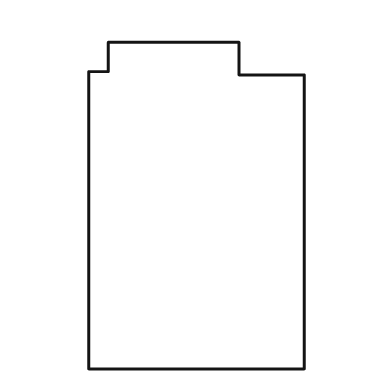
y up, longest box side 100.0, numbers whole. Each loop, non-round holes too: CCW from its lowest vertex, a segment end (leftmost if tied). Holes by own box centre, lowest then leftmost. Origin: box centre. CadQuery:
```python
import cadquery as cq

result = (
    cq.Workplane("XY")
    .moveTo(-33.0, -50.0)
    .lineTo(33.0, -50.0)
    .lineTo(33.0, 40.0)
    .lineTo(13.0, 40.0)
    .lineTo(13.0, 50.0)
    .lineTo(-27.0, 50.0)
    .lineTo(-27.0, 41.0)
    .lineTo(-33.0, 41.0)
    .close()
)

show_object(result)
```